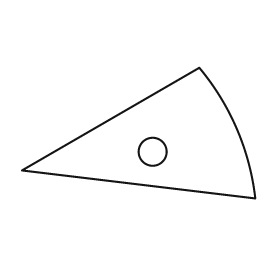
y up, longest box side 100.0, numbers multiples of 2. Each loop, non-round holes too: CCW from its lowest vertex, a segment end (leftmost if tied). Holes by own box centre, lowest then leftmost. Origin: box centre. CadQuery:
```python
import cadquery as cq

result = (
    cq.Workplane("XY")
    .moveTo(50.0, -28.0)
    .threePointArc((42.0, 2.0), (26.0, 28.0))
    .lineTo(-50.0, -16.0)
    .close()
    .moveTo(6.0, -8.0)
    .circle(6.0)
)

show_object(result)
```